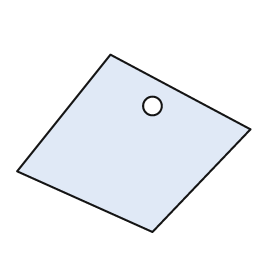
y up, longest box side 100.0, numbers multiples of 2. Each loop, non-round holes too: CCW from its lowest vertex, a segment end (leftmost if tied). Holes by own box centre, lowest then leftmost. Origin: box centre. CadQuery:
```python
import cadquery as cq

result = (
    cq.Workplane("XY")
    .moveTo(8.0, -38.0)
    .lineTo(50.0, 6.0)
    .lineTo(-10.0, 38.0)
    .lineTo(-50.0, -12.0)
    .close()
    .moveTo(8.0, 16.0)
    .circle(4.0)
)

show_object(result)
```